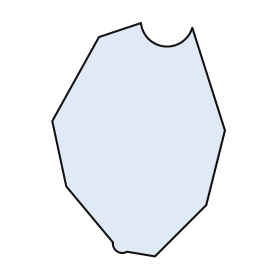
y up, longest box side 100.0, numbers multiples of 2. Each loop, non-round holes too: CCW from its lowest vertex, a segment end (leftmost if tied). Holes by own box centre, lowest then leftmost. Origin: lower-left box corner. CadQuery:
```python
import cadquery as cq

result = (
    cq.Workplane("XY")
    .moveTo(44.0, 0.0)
    .lineTo(66.0, 22.0)
    .lineTo(74.0, 54.0)
    .lineTo(60.0, 98.0)
    .threePointArc((48.0, 90.0), (38.0, 100.0))
    .lineTo(20.0, 94.0)
    .lineTo(0.0, 58.0)
    .lineTo(6.0, 30.0)
    .lineTo(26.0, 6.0)
    .threePointArc((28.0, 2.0), (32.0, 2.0))
    .close()
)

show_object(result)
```